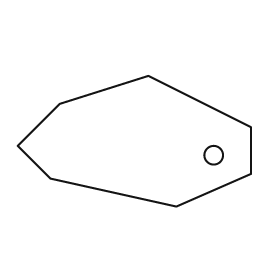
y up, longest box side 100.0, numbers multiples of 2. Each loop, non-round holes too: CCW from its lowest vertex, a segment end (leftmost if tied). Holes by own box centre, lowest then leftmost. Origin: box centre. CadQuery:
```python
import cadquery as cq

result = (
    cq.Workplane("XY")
    .moveTo(18.0, -28.0)
    .lineTo(50.0, -14.0)
    .lineTo(50.0, 6.0)
    .lineTo(6.0, 28.0)
    .lineTo(-32.0, 16.0)
    .lineTo(-50.0, -2.0)
    .lineTo(-36.0, -16.0)
    .close()
    .moveTo(34.0, -6.0)
    .circle(4.0)
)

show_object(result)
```